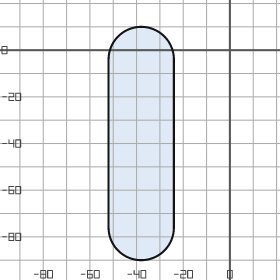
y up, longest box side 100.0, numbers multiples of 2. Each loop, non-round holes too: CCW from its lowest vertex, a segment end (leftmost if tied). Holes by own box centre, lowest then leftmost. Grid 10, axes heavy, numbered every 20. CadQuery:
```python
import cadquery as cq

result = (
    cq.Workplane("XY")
    .moveTo(-52.0, -76.0)
    .threePointArc((-38.0, -90.0), (-24.0, -76.0))
    .lineTo(-24.0, -4.0)
    .threePointArc((-38.0, 10.0), (-52.0, -4.0))
    .close()
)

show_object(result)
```